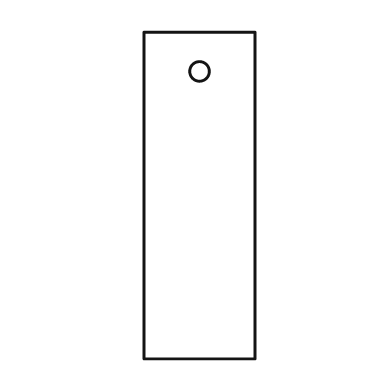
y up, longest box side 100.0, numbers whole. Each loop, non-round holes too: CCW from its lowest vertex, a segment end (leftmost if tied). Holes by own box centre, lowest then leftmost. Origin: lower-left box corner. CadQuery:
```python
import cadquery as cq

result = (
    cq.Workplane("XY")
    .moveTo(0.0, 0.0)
    .lineTo(34.0, 0.0)
    .lineTo(34.0, 100.0)
    .lineTo(0.0, 100.0)
    .close()
    .moveTo(17.0, 88.0)
    .circle(3.0)
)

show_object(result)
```